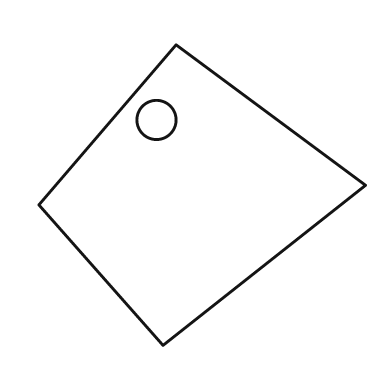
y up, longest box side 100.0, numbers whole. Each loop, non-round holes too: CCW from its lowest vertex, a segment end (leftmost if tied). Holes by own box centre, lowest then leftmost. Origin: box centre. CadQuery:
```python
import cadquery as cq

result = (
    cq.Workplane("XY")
    .moveTo(-12.0, -46.0)
    .lineTo(50.0, 3.0)
    .lineTo(-8.0, 46.0)
    .lineTo(-50.0, -3.0)
    .close()
    .moveTo(-14.0, 23.0)
    .circle(6.0)
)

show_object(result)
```